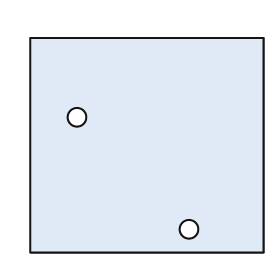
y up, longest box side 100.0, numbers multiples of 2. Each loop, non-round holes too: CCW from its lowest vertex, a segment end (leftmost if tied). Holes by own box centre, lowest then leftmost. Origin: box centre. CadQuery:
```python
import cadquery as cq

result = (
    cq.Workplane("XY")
    .moveTo(-50.0, -46.0)
    .lineTo(50.0, -46.0)
    .lineTo(50.0, 46.0)
    .lineTo(-50.0, 46.0)
    .close()
    .moveTo(18.0, -36.0)
    .circle(4.0)
    .moveTo(-30.0, 12.0)
    .circle(4.0)
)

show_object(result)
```